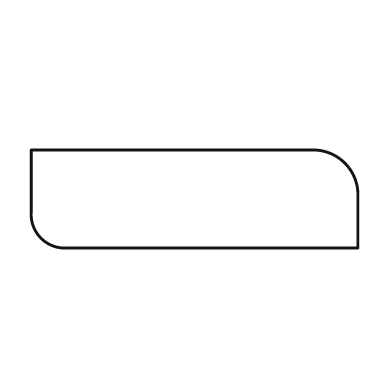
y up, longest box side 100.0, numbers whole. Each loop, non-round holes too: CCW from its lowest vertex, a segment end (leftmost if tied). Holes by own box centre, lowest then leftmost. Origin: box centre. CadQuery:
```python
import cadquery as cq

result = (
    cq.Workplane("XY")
    .moveTo(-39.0, -15.0)
    .lineTo(50.0, -15.0)
    .lineTo(50.0, 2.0)
    .threePointArc((46.0, 11.0), (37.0, 15.0))
    .lineTo(-50.0, 15.0)
    .lineTo(-50.0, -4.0)
    .threePointArc((-47.0, -12.0), (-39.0, -15.0))
    .close()
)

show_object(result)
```